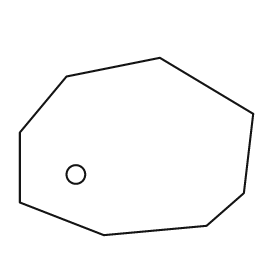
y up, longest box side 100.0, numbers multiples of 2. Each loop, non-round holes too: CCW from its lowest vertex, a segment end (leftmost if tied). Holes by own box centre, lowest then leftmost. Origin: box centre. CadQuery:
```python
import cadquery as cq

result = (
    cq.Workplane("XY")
    .moveTo(-14.0, -38.0)
    .lineTo(30.0, -34.0)
    .lineTo(46.0, -20.0)
    .lineTo(50.0, 14.0)
    .lineTo(10.0, 38.0)
    .lineTo(-30.0, 30.0)
    .lineTo(-50.0, 6.0)
    .lineTo(-50.0, -24.0)
    .close()
    .moveTo(-26.0, -12.0)
    .circle(4.0)
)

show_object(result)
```